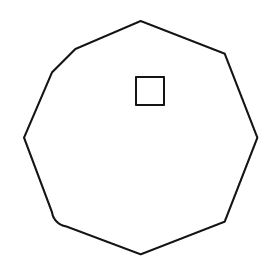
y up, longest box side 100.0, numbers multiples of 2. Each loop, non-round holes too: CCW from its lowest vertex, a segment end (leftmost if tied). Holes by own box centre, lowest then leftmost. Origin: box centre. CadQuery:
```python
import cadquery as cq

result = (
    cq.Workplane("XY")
    .moveTo(0.0, -50.0)
    .lineTo(36.0, -36.0)
    .lineTo(50.0, 0.0)
    .lineTo(36.0, 36.0)
    .lineTo(0.0, 50.0)
    .lineTo(-28.0, 38.0)
    .lineTo(-38.0, 28.0)
    .lineTo(-50.0, 0.0)
    .lineTo(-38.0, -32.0)
    .threePointArc((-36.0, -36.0), (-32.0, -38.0))
    .close()
    .moveTo(-2.0, 14.0)
    .lineTo(10.0, 14.0)
    .lineTo(10.0, 26.0)
    .lineTo(-2.0, 26.0)
    .close()
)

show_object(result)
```